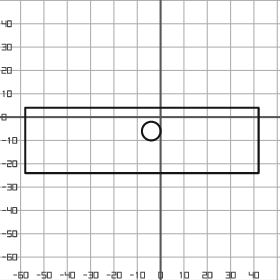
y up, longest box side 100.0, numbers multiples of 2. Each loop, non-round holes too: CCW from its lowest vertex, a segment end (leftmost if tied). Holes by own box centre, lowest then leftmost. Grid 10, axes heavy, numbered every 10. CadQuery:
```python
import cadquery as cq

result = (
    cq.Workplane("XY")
    .moveTo(-58.0, -24.0)
    .lineTo(42.0, -24.0)
    .lineTo(42.0, 4.0)
    .lineTo(-58.0, 4.0)
    .close()
    .moveTo(-4.0, -6.0)
    .circle(4.0)
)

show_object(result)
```